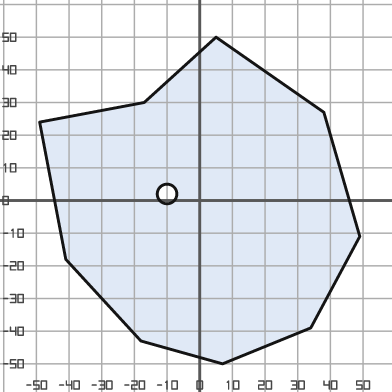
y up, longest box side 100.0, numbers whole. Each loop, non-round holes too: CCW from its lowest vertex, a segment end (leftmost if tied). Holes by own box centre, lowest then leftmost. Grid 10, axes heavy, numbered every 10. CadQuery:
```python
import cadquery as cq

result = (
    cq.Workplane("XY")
    .moveTo(7.0, -50.0)
    .lineTo(34.0, -39.0)
    .lineTo(49.0, -11.0)
    .lineTo(38.0, 27.0)
    .lineTo(5.0, 50.0)
    .lineTo(-17.0, 30.0)
    .lineTo(-49.0, 24.0)
    .lineTo(-41.0, -18.0)
    .lineTo(-18.0, -43.0)
    .close()
    .moveTo(-10.0, 2.0)
    .circle(3.0)
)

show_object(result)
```